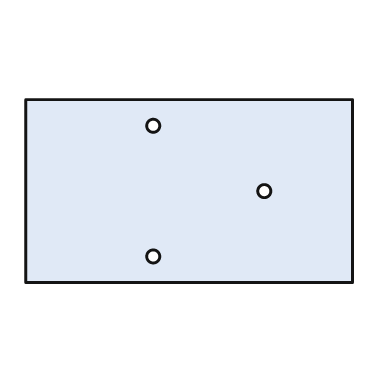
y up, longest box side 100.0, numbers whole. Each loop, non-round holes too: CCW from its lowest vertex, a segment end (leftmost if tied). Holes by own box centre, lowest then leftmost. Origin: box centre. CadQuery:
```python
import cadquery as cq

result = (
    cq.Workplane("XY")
    .moveTo(-50.0, -28.0)
    .lineTo(50.0, -28.0)
    .lineTo(50.0, 28.0)
    .lineTo(-50.0, 28.0)
    .close()
    .moveTo(-11.0, -20.0)
    .circle(2.0)
    .moveTo(23.0, 0.0)
    .circle(2.0)
    .moveTo(-11.0, 20.0)
    .circle(2.0)
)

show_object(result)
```